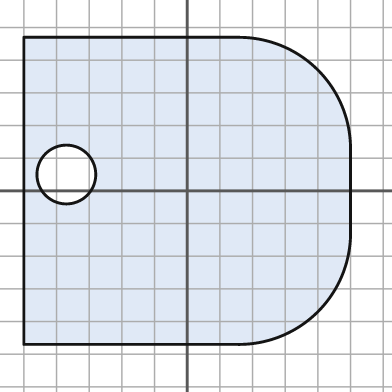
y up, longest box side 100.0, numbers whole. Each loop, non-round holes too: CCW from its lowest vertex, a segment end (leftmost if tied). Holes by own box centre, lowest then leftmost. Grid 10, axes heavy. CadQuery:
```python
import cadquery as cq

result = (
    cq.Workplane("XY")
    .moveTo(-50.0, -47.0)
    .lineTo(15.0, -47.0)
    .threePointArc((40.0, -37.0), (50.0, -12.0))
    .lineTo(50.0, 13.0)
    .threePointArc((40.0, 37.0), (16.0, 47.0))
    .lineTo(-50.0, 47.0)
    .close()
    .moveTo(-37.0, 5.0)
    .circle(9.0)
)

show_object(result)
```